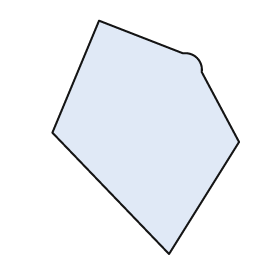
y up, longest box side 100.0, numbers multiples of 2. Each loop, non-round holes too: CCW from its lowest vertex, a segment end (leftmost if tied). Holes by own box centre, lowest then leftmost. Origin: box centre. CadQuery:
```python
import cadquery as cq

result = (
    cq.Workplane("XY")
    .moveTo(10.0, -50.0)
    .lineTo(40.0, -2.0)
    .lineTo(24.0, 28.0)
    .threePointArc((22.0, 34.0), (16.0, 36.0))
    .lineTo(-20.0, 50.0)
    .lineTo(-40.0, 2.0)
    .close()
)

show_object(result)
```